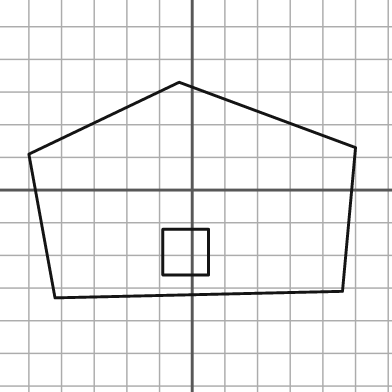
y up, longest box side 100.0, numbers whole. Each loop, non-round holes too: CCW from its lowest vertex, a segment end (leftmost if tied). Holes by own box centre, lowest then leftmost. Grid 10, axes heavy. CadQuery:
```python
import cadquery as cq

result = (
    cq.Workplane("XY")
    .moveTo(-42.0, -33.0)
    .lineTo(46.0, -31.0)
    .lineTo(50.0, 13.0)
    .lineTo(-4.0, 33.0)
    .lineTo(-50.0, 11.0)
    .close()
    .moveTo(-9.0, -26.0)
    .lineTo(5.0, -26.0)
    .lineTo(5.0, -12.0)
    .lineTo(-9.0, -12.0)
    .close()
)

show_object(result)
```